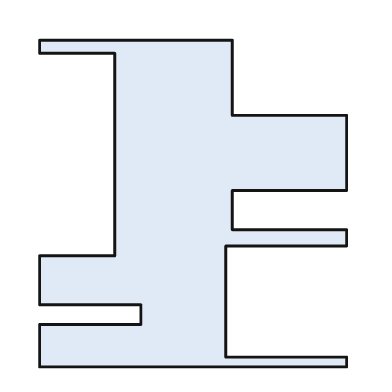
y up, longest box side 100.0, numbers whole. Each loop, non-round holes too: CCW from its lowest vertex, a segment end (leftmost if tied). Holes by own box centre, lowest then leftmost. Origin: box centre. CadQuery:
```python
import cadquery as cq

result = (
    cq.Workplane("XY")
    .moveTo(-47.0, -50.0)
    .lineTo(47.0, -50.0)
    .lineTo(47.0, -47.0)
    .lineTo(10.0, -47.0)
    .lineTo(10.0, -13.0)
    .lineTo(47.0, -13.0)
    .lineTo(47.0, -8.0)
    .lineTo(12.0, -8.0)
    .lineTo(12.0, 4.0)
    .lineTo(47.0, 4.0)
    .lineTo(47.0, 27.0)
    .lineTo(12.0, 27.0)
    .lineTo(12.0, 50.0)
    .lineTo(-47.0, 50.0)
    .lineTo(-47.0, 46.0)
    .lineTo(-24.0, 46.0)
    .lineTo(-24.0, -16.0)
    .lineTo(-47.0, -16.0)
    .lineTo(-47.0, -31.0)
    .lineTo(-16.0, -31.0)
    .lineTo(-16.0, -37.0)
    .lineTo(-47.0, -37.0)
    .close()
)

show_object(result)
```